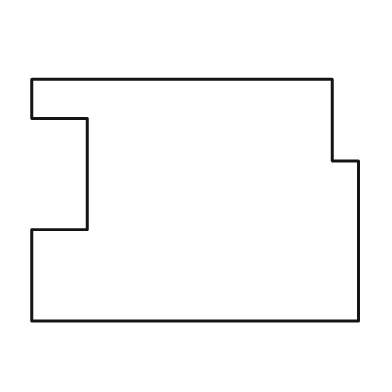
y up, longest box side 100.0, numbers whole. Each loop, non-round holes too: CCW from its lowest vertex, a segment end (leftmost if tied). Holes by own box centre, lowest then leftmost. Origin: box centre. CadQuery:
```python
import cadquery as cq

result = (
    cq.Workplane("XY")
    .moveTo(-50.0, -37.0)
    .lineTo(50.0, -37.0)
    .lineTo(50.0, 12.0)
    .lineTo(42.0, 12.0)
    .lineTo(42.0, 37.0)
    .lineTo(-50.0, 37.0)
    .lineTo(-50.0, 25.0)
    .lineTo(-33.0, 25.0)
    .lineTo(-33.0, -9.0)
    .lineTo(-50.0, -9.0)
    .close()
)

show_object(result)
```